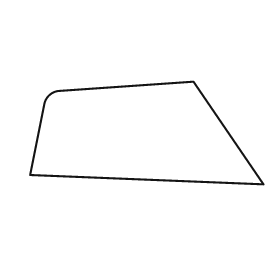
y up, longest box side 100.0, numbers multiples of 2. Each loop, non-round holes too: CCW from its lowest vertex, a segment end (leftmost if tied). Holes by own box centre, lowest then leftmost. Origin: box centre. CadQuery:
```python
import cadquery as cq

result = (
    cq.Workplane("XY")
    .moveTo(50.0, -22.0)
    .lineTo(20.0, 22.0)
    .lineTo(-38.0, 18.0)
    .threePointArc((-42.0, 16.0), (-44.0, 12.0))
    .lineTo(-50.0, -18.0)
    .close()
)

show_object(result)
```